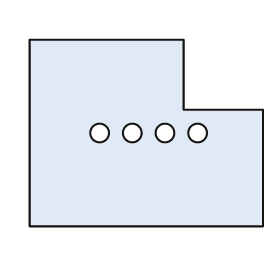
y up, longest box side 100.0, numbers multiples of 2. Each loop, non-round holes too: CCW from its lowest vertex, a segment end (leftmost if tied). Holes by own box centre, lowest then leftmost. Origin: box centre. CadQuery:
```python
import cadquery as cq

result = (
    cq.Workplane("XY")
    .moveTo(-50.0, -40.0)
    .lineTo(50.0, -40.0)
    .lineTo(50.0, 10.0)
    .lineTo(16.0, 10.0)
    .lineTo(16.0, 40.0)
    .lineTo(-50.0, 40.0)
    .close()
    .moveTo(-20.0, 0.0)
    .circle(4.0)
    .moveTo(-6.0, 0.0)
    .circle(4.0)
    .moveTo(8.0, 0.0)
    .circle(4.0)
    .moveTo(22.0, 0.0)
    .circle(4.0)
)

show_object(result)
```